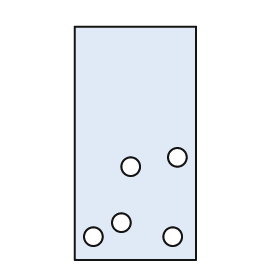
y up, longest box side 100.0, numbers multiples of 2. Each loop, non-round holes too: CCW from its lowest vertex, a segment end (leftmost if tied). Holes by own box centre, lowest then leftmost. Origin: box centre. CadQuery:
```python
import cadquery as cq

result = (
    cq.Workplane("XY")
    .moveTo(-26.0, -50.0)
    .lineTo(26.0, -50.0)
    .lineTo(26.0, 50.0)
    .lineTo(-26.0, 50.0)
    .close()
    .moveTo(-18.0, -40.0)
    .circle(4.0)
    .moveTo(16.0, -40.0)
    .circle(4.0)
    .moveTo(-6.0, -34.0)
    .circle(4.0)
    .moveTo(-2.0, -10.0)
    .circle(4.0)
    .moveTo(18.0, -6.0)
    .circle(4.0)
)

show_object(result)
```